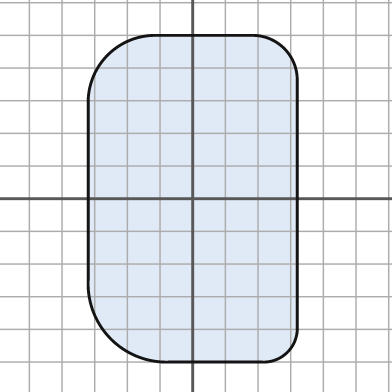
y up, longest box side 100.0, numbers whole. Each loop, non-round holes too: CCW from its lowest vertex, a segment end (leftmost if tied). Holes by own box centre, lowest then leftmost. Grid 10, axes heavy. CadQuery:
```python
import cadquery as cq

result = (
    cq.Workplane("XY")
    .moveTo(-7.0, -50.0)
    .lineTo(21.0, -50.0)
    .threePointArc((29.0, -47.0), (32.0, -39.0))
    .lineTo(32.0, 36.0)
    .threePointArc((28.0, 46.0), (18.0, 50.0))
    .lineTo(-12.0, 50.0)
    .threePointArc((-26.0, 44.0), (-32.0, 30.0))
    .lineTo(-32.0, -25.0)
    .threePointArc((-25.0, -43.0), (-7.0, -50.0))
    .close()
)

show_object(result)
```